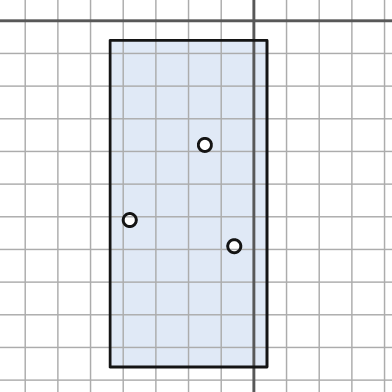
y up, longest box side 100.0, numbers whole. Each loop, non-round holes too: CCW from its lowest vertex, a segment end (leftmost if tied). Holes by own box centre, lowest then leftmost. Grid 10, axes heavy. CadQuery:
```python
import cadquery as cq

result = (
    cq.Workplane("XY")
    .moveTo(-44.0, -106.0)
    .lineTo(4.0, -106.0)
    .lineTo(4.0, -6.0)
    .lineTo(-44.0, -6.0)
    .close()
    .moveTo(-6.0, -69.0)
    .circle(2.0)
    .moveTo(-38.0, -61.0)
    .circle(2.0)
    .moveTo(-15.0, -38.0)
    .circle(2.0)
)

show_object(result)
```